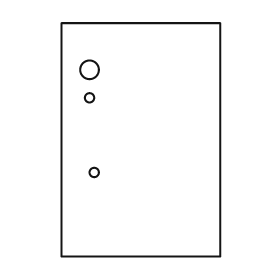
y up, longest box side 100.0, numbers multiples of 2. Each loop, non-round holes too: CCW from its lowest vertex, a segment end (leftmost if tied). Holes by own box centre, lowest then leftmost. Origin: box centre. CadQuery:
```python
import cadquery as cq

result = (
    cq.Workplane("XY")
    .moveTo(-34.0, -50.0)
    .lineTo(34.0, -50.0)
    .lineTo(34.0, 50.0)
    .lineTo(-34.0, 50.0)
    .close()
    .moveTo(-20.0, -14.0)
    .circle(2.0)
    .moveTo(-22.0, 18.0)
    .circle(2.0)
    .moveTo(-22.0, 30.0)
    .circle(4.0)
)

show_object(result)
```